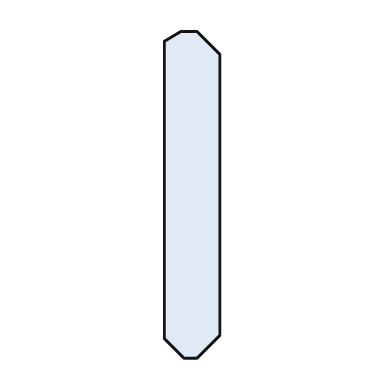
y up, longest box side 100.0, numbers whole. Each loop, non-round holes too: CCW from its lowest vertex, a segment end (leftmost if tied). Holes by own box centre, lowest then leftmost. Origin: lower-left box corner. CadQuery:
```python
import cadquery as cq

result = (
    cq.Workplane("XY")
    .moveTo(6.0, 0.0)
    .lineTo(10.0, 0.0)
    .lineTo(17.0, 7.0)
    .lineTo(17.0, 93.0)
    .lineTo(10.0, 100.0)
    .lineTo(5.0, 100.0)
    .lineTo(0.0, 97.0)
    .lineTo(0.0, 6.0)
    .close()
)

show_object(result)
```